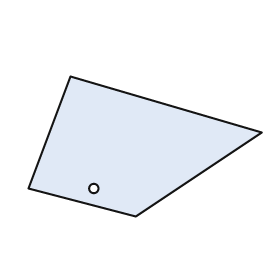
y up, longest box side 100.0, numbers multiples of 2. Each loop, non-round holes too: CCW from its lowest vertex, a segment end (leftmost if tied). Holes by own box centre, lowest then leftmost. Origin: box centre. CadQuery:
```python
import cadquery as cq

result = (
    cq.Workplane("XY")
    .moveTo(-4.0, -30.0)
    .lineTo(50.0, 6.0)
    .lineTo(-32.0, 30.0)
    .lineTo(-50.0, -18.0)
    .close()
    .moveTo(-22.0, -18.0)
    .circle(2.0)
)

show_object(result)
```